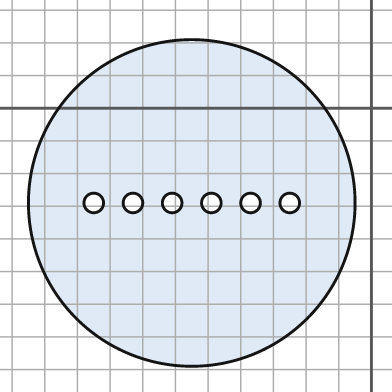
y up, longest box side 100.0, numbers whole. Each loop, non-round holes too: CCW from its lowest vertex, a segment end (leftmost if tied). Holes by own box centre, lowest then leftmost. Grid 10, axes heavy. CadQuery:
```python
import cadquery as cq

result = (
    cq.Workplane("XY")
    .moveTo(-55.0, -29.0)
    .circle(50.0)
    .moveTo(-85.0, -29.0)
    .circle(3.0)
    .moveTo(-73.0, -29.0)
    .circle(3.0)
    .moveTo(-61.0, -29.0)
    .circle(3.0)
    .moveTo(-49.0, -29.0)
    .circle(3.0)
    .moveTo(-37.0, -29.0)
    .circle(3.0)
    .moveTo(-25.0, -29.0)
    .circle(3.0)
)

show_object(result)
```